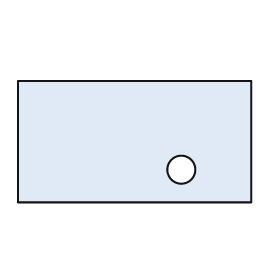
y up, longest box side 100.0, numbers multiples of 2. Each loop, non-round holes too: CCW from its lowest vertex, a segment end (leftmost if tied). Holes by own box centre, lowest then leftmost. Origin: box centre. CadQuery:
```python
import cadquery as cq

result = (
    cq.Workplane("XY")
    .moveTo(-50.0, -26.0)
    .lineTo(50.0, -26.0)
    .lineTo(50.0, 26.0)
    .lineTo(-50.0, 26.0)
    .close()
    .moveTo(20.0, -12.0)
    .circle(6.0)
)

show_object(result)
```